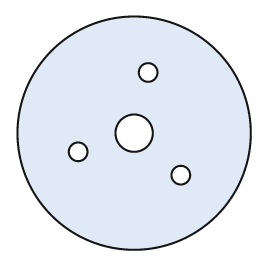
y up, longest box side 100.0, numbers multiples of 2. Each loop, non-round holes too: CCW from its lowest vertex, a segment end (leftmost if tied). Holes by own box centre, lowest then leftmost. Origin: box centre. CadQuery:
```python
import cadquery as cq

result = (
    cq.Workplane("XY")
    .moveTo(0.0, 0.0)
    .circle(50.0)
    .moveTo(20.0, -18.0)
    .circle(4.0)
    .moveTo(-24.0, -8.0)
    .circle(4.0)
    .moveTo(0.0, 0.0)
    .circle(8.0)
    .moveTo(6.0, 26.0)
    .circle(4.0)
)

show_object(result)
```